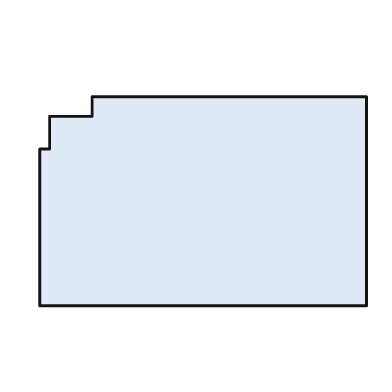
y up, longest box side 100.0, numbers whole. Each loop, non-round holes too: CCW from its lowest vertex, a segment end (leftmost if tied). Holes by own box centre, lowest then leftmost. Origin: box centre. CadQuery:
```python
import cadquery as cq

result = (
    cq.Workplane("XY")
    .moveTo(-50.0, -32.0)
    .lineTo(50.0, -32.0)
    .lineTo(50.0, 32.0)
    .lineTo(-34.0, 32.0)
    .lineTo(-34.0, 26.0)
    .lineTo(-47.0, 26.0)
    .lineTo(-47.0, 16.0)
    .lineTo(-50.0, 16.0)
    .close()
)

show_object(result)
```